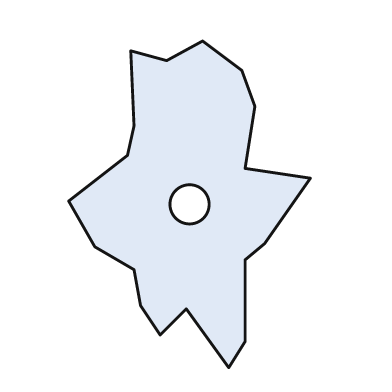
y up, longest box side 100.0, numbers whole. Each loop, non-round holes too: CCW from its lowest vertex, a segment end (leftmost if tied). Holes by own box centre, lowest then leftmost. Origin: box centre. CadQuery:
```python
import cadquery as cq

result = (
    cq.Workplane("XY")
    .moveTo(12.0, -50.0)
    .lineTo(17.0, -42.0)
    .lineTo(17.0, -17.0)
    .lineTo(23.0, -12.0)
    .lineTo(37.0, 8.0)
    .lineTo(17.0, 11.0)
    .lineTo(20.0, 30.0)
    .lineTo(16.0, 41.0)
    .lineTo(4.0, 50.0)
    .lineTo(-7.0, 44.0)
    .lineTo(-18.0, 47.0)
    .lineTo(-17.0, 24.0)
    .lineTo(-19.0, 15.0)
    .lineTo(-37.0, 1.0)
    .lineTo(-29.0, -13.0)
    .lineTo(-17.0, -20.0)
    .lineTo(-15.0, -31.0)
    .lineTo(-9.0, -40.0)
    .lineTo(-1.0, -32.0)
    .close()
    .moveTo(0.0, 0.0)
    .circle(6.0)
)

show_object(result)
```